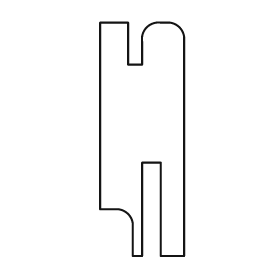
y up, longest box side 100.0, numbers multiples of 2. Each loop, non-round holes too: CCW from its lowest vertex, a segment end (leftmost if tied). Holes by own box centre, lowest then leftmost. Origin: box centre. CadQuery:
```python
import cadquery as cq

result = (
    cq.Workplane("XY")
    .moveTo(-4.0, -50.0)
    .lineTo(0.0, -50.0)
    .lineTo(0.0, -10.0)
    .lineTo(8.0, -10.0)
    .lineTo(8.0, -50.0)
    .lineTo(18.0, -50.0)
    .lineTo(18.0, 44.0)
    .threePointArc((16.0, 48.0), (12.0, 50.0))
    .lineTo(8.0, 50.0)
    .threePointArc((2.0, 48.0), (0.0, 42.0))
    .lineTo(0.0, 32.0)
    .lineTo(-6.0, 32.0)
    .lineTo(-6.0, 50.0)
    .lineTo(-18.0, 50.0)
    .lineTo(-18.0, -30.0)
    .lineTo(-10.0, -30.0)
    .threePointArc((-6.0, -32.0), (-4.0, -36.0))
    .close()
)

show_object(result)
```